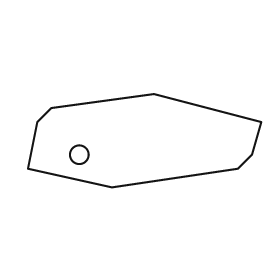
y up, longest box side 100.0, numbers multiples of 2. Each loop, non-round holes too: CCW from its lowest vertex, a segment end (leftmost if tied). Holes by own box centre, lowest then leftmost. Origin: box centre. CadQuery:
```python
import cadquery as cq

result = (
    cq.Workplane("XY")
    .moveTo(-14.0, -20.0)
    .lineTo(40.0, -12.0)
    .lineTo(46.0, -6.0)
    .lineTo(50.0, 8.0)
    .lineTo(4.0, 20.0)
    .lineTo(-40.0, 14.0)
    .lineTo(-46.0, 8.0)
    .lineTo(-50.0, -12.0)
    .close()
    .moveTo(-28.0, -6.0)
    .circle(4.0)
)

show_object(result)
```